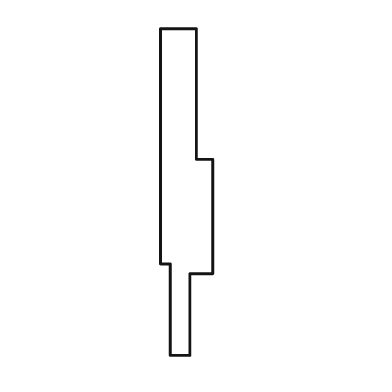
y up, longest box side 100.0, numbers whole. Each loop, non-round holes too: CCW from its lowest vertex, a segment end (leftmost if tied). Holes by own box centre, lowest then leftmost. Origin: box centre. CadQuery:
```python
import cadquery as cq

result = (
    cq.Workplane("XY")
    .moveTo(-5.0, -50.0)
    .lineTo(1.0, -50.0)
    .lineTo(1.0, -25.0)
    .lineTo(8.0, -25.0)
    .lineTo(8.0, 10.0)
    .lineTo(3.0, 10.0)
    .lineTo(3.0, 50.0)
    .lineTo(-8.0, 50.0)
    .lineTo(-8.0, -22.0)
    .lineTo(-5.0, -22.0)
    .close()
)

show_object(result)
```